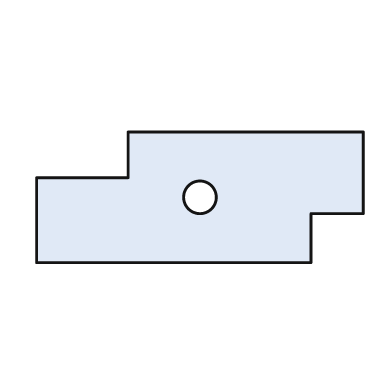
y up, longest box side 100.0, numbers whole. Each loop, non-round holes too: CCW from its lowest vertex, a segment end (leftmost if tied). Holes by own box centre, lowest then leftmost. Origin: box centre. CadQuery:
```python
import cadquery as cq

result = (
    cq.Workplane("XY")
    .moveTo(-50.0, -20.0)
    .lineTo(34.0, -20.0)
    .lineTo(34.0, -5.0)
    .lineTo(50.0, -5.0)
    .lineTo(50.0, 20.0)
    .lineTo(-22.0, 20.0)
    .lineTo(-22.0, 6.0)
    .lineTo(-50.0, 6.0)
    .close()
    .moveTo(0.0, 0.0)
    .circle(5.0)
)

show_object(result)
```